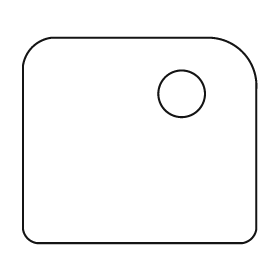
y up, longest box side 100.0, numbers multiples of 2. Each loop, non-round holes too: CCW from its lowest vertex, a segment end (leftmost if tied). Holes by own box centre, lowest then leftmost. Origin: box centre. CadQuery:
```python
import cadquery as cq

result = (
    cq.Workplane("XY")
    .moveTo(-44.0, -44.0)
    .lineTo(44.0, -44.0)
    .threePointArc((48.0, -42.0), (50.0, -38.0))
    .lineTo(50.0, 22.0)
    .threePointArc((44.0, 38.0), (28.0, 44.0))
    .lineTo(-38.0, 44.0)
    .threePointArc((-46.0, 40.0), (-50.0, 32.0))
    .lineTo(-50.0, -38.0)
    .threePointArc((-48.0, -42.0), (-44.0, -44.0))
    .close()
    .moveTo(18.0, 20.0)
    .circle(10.0)
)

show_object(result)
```